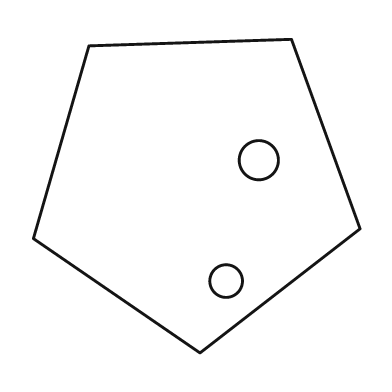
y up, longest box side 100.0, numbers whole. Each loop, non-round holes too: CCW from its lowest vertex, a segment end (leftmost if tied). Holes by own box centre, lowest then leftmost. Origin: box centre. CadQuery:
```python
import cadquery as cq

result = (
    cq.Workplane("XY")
    .moveTo(1.0, -48.0)
    .lineTo(50.0, -10.0)
    .lineTo(29.0, 48.0)
    .lineTo(-33.0, 46.0)
    .lineTo(-50.0, -13.0)
    .close()
    .moveTo(9.0, -26.0)
    .circle(5.0)
    .moveTo(19.0, 11.0)
    .circle(6.0)
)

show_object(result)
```